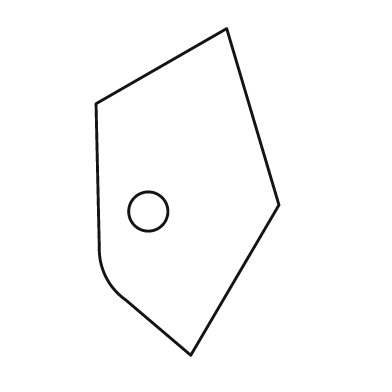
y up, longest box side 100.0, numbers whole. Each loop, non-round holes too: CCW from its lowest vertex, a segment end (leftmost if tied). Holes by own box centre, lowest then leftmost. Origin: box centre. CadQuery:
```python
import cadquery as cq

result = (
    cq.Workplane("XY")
    .moveTo(1.0, -50.0)
    .lineTo(28.0, -4.0)
    .lineTo(12.0, 50.0)
    .lineTo(-28.0, 27.0)
    .lineTo(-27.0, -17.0)
    .threePointArc((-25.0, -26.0), (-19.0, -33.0))
    .close()
    .moveTo(-12.0, -6.0)
    .circle(6.0)
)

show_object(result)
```